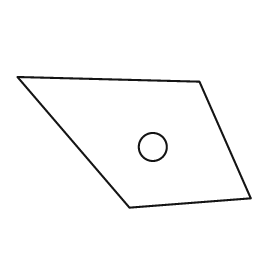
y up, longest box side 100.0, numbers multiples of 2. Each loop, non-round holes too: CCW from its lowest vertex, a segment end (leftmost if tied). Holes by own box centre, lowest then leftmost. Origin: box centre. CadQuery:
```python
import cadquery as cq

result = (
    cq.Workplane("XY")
    .moveTo(-2.0, -28.0)
    .lineTo(50.0, -24.0)
    .lineTo(28.0, 26.0)
    .lineTo(-50.0, 28.0)
    .close()
    .moveTo(8.0, -2.0)
    .circle(6.0)
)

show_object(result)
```